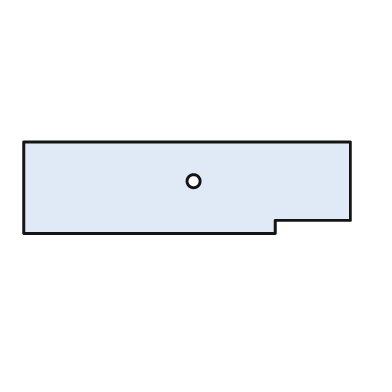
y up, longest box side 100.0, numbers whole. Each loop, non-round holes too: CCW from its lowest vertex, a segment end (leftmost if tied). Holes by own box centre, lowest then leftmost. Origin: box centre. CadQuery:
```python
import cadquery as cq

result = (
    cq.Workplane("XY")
    .moveTo(-50.0, -14.0)
    .lineTo(27.0, -14.0)
    .lineTo(27.0, -10.0)
    .lineTo(50.0, -10.0)
    .lineTo(50.0, 14.0)
    .lineTo(-50.0, 14.0)
    .close()
    .moveTo(2.0, 2.0)
    .circle(2.0)
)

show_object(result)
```